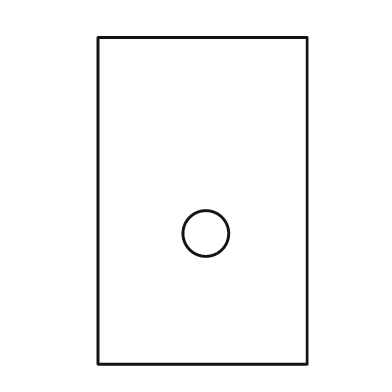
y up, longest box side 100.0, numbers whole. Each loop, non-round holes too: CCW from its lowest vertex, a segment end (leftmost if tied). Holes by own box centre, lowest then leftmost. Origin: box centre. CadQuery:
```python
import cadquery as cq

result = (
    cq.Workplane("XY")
    .moveTo(-32.0, -50.0)
    .lineTo(32.0, -50.0)
    .lineTo(32.0, 50.0)
    .lineTo(-32.0, 50.0)
    .close()
    .moveTo(1.0, -10.0)
    .circle(7.0)
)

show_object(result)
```